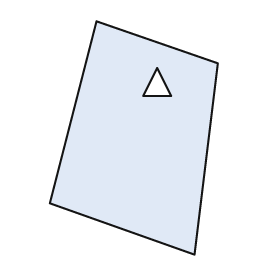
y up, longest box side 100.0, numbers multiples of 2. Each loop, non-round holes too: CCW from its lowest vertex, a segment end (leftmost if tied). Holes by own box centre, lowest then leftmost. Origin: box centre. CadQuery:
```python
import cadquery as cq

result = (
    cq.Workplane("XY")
    .moveTo(26.0, -50.0)
    .lineTo(36.0, 32.0)
    .lineTo(-16.0, 50.0)
    .lineTo(-36.0, -28.0)
    .close()
    .moveTo(4.0, 18.0)
    .lineTo(16.0, 18.0)
    .lineTo(10.0, 30.0)
    .close()
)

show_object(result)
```